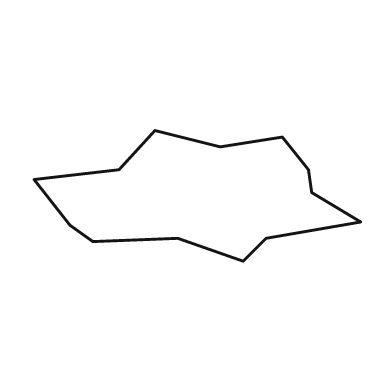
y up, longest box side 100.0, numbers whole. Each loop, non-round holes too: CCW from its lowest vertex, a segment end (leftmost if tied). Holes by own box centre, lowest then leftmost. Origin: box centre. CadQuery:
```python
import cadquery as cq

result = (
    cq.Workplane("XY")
    .moveTo(14.0, -20.0)
    .lineTo(21.0, -13.0)
    .lineTo(50.0, -8.0)
    .lineTo(35.0, 1.0)
    .lineTo(34.0, 8.0)
    .lineTo(26.0, 18.0)
    .lineTo(7.0, 15.0)
    .lineTo(-13.0, 20.0)
    .lineTo(-24.0, 8.0)
    .lineTo(-50.0, 5.0)
    .lineTo(-39.0, -9.0)
    .lineTo(-32.0, -14.0)
    .lineTo(-6.0, -13.0)
    .close()
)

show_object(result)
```